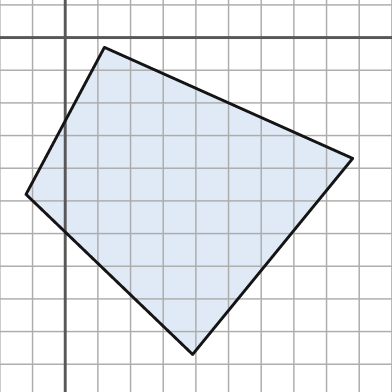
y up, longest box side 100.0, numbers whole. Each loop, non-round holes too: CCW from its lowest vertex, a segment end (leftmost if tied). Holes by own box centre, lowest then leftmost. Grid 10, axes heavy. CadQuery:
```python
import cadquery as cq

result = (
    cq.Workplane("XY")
    .moveTo(39.0, -97.0)
    .lineTo(88.0, -37.0)
    .lineTo(12.0, -3.0)
    .lineTo(-12.0, -48.0)
    .close()
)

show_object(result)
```